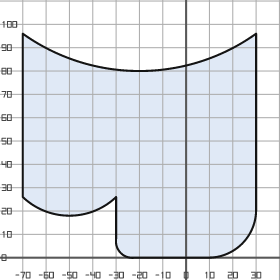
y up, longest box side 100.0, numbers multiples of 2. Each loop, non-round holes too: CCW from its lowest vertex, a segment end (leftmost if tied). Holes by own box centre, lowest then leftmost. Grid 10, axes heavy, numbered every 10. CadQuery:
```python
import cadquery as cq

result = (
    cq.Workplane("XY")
    .moveTo(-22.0, 0.0)
    .lineTo(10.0, 0.0)
    .threePointArc((24.0, 6.0), (30.0, 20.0))
    .lineTo(30.0, 96.0)
    .threePointArc((-20.0, 80.0), (-70.0, 96.0))
    .lineTo(-70.0, 26.0)
    .threePointArc((-50.0, 18.0), (-30.0, 26.0))
    .lineTo(-30.0, 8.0)
    .threePointArc((-28.0, 2.0), (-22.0, 0.0))
    .close()
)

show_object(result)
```